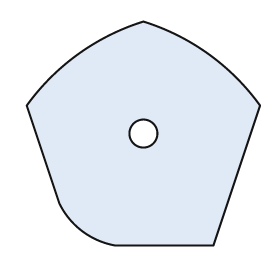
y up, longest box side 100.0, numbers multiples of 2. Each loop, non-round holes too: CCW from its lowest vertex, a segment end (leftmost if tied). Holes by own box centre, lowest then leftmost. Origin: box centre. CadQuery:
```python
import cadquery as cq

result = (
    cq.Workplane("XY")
    .moveTo(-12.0, -48.0)
    .lineTo(30.0, -48.0)
    .lineTo(50.0, 12.0)
    .threePointArc((28.0, 34.0), (0.0, 48.0))
    .threePointArc((-28.0, 34.0), (-50.0, 12.0))
    .lineTo(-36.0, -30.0)
    .threePointArc((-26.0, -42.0), (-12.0, -48.0))
    .close()
    .moveTo(0.0, 0.0)
    .circle(6.0)
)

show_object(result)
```